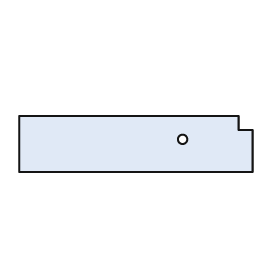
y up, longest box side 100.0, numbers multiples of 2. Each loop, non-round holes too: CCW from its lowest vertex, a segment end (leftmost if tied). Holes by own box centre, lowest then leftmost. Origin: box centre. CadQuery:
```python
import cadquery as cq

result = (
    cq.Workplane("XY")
    .moveTo(-50.0, -12.0)
    .lineTo(50.0, -12.0)
    .lineTo(50.0, 6.0)
    .lineTo(44.0, 6.0)
    .lineTo(44.0, 12.0)
    .lineTo(-50.0, 12.0)
    .close()
    .moveTo(20.0, 2.0)
    .circle(2.0)
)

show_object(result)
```